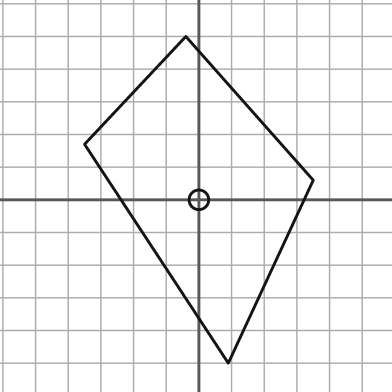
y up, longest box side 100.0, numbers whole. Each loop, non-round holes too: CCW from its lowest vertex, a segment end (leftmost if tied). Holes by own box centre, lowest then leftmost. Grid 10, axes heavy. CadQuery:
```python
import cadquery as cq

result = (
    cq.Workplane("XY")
    .moveTo(9.0, -50.0)
    .lineTo(35.0, 6.0)
    .lineTo(-4.0, 50.0)
    .lineTo(-35.0, 17.0)
    .close()
    .moveTo(0.0, 0.0)
    .circle(3.0)
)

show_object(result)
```